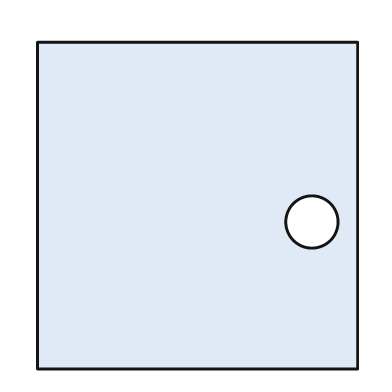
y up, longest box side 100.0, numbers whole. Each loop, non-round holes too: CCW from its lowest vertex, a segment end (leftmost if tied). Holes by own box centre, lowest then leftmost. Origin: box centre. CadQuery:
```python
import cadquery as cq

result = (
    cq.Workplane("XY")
    .moveTo(-49.0, -50.0)
    .lineTo(49.0, -50.0)
    .lineTo(49.0, 50.0)
    .lineTo(-49.0, 50.0)
    .close()
    .moveTo(35.0, -5.0)
    .circle(8.0)
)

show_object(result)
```